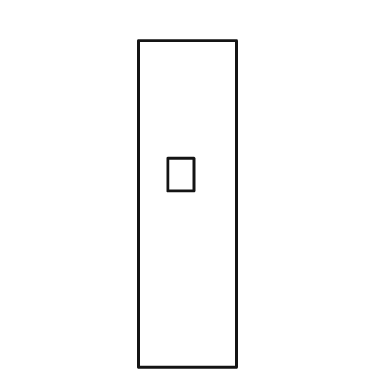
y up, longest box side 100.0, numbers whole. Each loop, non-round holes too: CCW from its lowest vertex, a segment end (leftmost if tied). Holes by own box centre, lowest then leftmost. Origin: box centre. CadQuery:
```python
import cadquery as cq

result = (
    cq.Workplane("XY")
    .moveTo(-15.0, -50.0)
    .lineTo(15.0, -50.0)
    .lineTo(15.0, 50.0)
    .lineTo(-15.0, 50.0)
    .close()
    .moveTo(-6.0, 4.0)
    .lineTo(2.0, 4.0)
    .lineTo(2.0, 14.0)
    .lineTo(-6.0, 14.0)
    .close()
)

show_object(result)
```